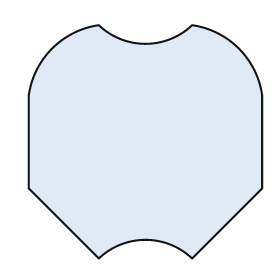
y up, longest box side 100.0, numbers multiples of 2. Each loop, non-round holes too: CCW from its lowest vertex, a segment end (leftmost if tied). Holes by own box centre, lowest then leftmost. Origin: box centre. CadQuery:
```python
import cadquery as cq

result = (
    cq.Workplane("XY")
    .moveTo(-20.0, -50.0)
    .threePointArc((0.0, -42.0), (20.0, -50.0))
    .lineTo(50.0, -20.0)
    .lineTo(50.0, 20.0)
    .threePointArc((40.0, 40.0), (20.0, 50.0))
    .threePointArc((0.0, 42.0), (-20.0, 50.0))
    .threePointArc((-40.0, 40.0), (-50.0, 20.0))
    .lineTo(-50.0, -20.0)
    .close()
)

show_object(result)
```